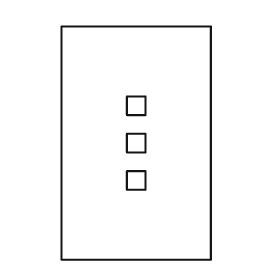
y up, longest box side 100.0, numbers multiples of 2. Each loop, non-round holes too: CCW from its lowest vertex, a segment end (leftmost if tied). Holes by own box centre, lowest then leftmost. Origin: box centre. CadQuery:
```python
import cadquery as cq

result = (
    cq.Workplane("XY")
    .moveTo(-32.0, -50.0)
    .lineTo(32.0, -50.0)
    .lineTo(32.0, 50.0)
    .lineTo(-32.0, 50.0)
    .close()
    .moveTo(-4.0, -20.0)
    .lineTo(4.0, -20.0)
    .lineTo(4.0, -12.0)
    .lineTo(-4.0, -12.0)
    .close()
    .moveTo(-4.0, -4.0)
    .lineTo(4.0, -4.0)
    .lineTo(4.0, 4.0)
    .lineTo(-4.0, 4.0)
    .close()
    .moveTo(-4.0, 12.0)
    .lineTo(4.0, 12.0)
    .lineTo(4.0, 20.0)
    .lineTo(-4.0, 20.0)
    .close()
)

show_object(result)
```